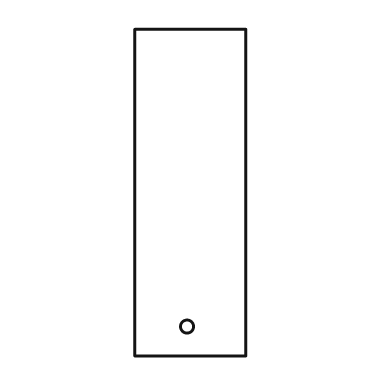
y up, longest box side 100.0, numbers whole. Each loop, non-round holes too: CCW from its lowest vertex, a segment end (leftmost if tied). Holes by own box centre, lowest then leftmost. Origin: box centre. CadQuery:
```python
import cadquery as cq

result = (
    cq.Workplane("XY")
    .moveTo(-17.0, -50.0)
    .lineTo(17.0, -50.0)
    .lineTo(17.0, 50.0)
    .lineTo(-17.0, 50.0)
    .close()
    .moveTo(-1.0, -41.0)
    .circle(2.0)
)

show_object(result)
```